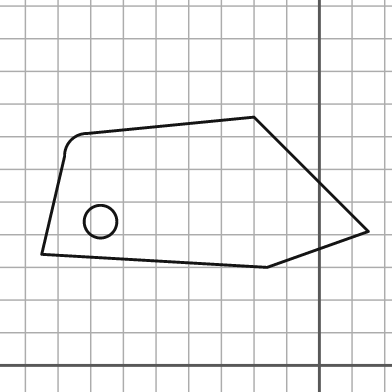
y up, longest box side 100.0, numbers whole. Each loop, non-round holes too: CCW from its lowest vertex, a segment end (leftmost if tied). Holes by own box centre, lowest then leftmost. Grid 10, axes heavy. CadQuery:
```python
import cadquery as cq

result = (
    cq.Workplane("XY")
    .moveTo(-16.0, 30.0)
    .lineTo(15.0, 41.0)
    .lineTo(-20.0, 76.0)
    .lineTo(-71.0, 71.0)
    .threePointArc((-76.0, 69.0), (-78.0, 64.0))
    .lineTo(-85.0, 34.0)
    .close()
    .moveTo(-67.0, 44.0)
    .circle(5.0)
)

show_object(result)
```